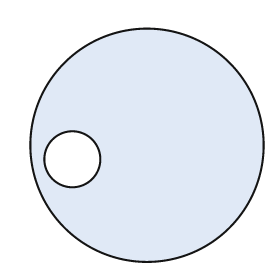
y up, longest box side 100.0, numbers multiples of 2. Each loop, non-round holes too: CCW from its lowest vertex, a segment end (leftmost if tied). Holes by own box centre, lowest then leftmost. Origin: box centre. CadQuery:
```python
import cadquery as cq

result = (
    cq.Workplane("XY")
    .moveTo(0.0, 0.0)
    .circle(50.0)
    .moveTo(-32.0, -6.0)
    .circle(12.0)
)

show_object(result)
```